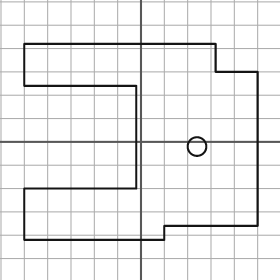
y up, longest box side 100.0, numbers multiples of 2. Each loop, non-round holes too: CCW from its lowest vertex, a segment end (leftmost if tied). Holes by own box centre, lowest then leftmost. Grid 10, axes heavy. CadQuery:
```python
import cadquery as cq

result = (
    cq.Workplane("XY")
    .moveTo(-50.0, -42.0)
    .lineTo(10.0, -42.0)
    .lineTo(10.0, -36.0)
    .lineTo(50.0, -36.0)
    .lineTo(50.0, 30.0)
    .lineTo(32.0, 30.0)
    .lineTo(32.0, 42.0)
    .lineTo(-50.0, 42.0)
    .lineTo(-50.0, 24.0)
    .lineTo(-2.0, 24.0)
    .lineTo(-2.0, -20.0)
    .lineTo(-50.0, -20.0)
    .close()
    .moveTo(24.0, -2.0)
    .circle(4.0)
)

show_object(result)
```